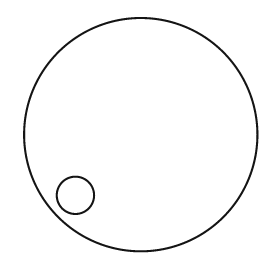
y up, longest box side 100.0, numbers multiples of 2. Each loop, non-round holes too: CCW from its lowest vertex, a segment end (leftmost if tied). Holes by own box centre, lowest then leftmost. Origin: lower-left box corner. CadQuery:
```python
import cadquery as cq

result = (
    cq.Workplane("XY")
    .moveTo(50.0, 50.0)
    .circle(50.0)
    .moveTo(22.0, 24.0)
    .circle(8.0)
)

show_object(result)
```